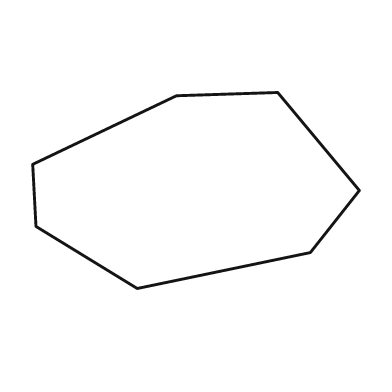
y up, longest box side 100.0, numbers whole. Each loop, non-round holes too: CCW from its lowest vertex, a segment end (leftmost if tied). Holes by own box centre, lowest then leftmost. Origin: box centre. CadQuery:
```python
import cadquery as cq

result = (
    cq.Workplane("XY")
    .moveTo(-18.0, -30.0)
    .lineTo(35.0, -19.0)
    .lineTo(50.0, 0.0)
    .lineTo(25.0, 30.0)
    .lineTo(-6.0, 29.0)
    .lineTo(-50.0, 8.0)
    .lineTo(-49.0, -11.0)
    .close()
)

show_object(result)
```